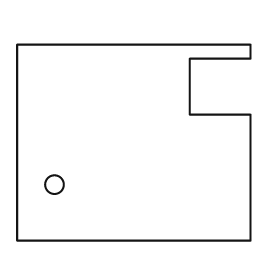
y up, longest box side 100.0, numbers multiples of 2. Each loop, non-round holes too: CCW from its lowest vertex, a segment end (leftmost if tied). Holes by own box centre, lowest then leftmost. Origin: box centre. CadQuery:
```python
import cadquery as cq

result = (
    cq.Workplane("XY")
    .moveTo(-50.0, -42.0)
    .lineTo(50.0, -42.0)
    .lineTo(50.0, 12.0)
    .lineTo(24.0, 12.0)
    .lineTo(24.0, 36.0)
    .lineTo(50.0, 36.0)
    .lineTo(50.0, 42.0)
    .lineTo(-50.0, 42.0)
    .close()
    .moveTo(-34.0, -18.0)
    .circle(4.0)
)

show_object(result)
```